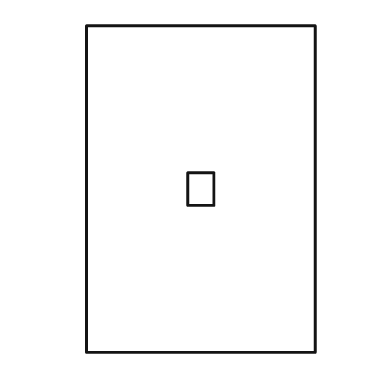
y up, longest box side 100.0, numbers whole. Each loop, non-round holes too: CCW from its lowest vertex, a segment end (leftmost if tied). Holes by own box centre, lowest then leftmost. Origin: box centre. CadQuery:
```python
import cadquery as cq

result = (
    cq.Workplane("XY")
    .moveTo(-35.0, -50.0)
    .lineTo(35.0, -50.0)
    .lineTo(35.0, 50.0)
    .lineTo(-35.0, 50.0)
    .close()
    .moveTo(-4.0, -5.0)
    .lineTo(4.0, -5.0)
    .lineTo(4.0, 5.0)
    .lineTo(-4.0, 5.0)
    .close()
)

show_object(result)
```